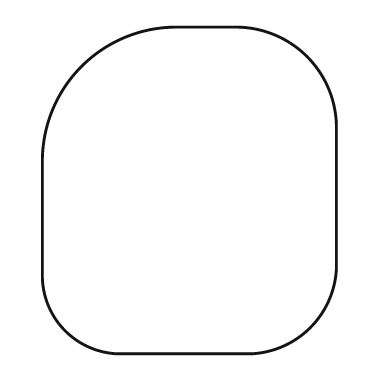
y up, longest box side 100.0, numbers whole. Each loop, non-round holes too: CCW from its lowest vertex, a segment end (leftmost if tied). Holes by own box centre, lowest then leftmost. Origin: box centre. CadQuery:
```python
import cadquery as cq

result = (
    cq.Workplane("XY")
    .moveTo(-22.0, -50.0)
    .lineTo(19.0, -50.0)
    .threePointArc((37.0, -42.0), (45.0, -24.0))
    .lineTo(45.0, 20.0)
    .threePointArc((36.0, 41.0), (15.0, 50.0))
    .lineTo(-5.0, 50.0)
    .threePointArc((-33.0, 38.0), (-45.0, 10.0))
    .lineTo(-45.0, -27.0)
    .threePointArc((-38.0, -43.0), (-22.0, -50.0))
    .close()
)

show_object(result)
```